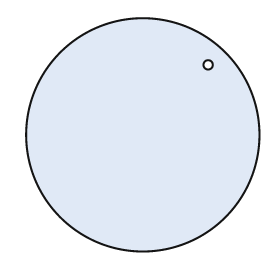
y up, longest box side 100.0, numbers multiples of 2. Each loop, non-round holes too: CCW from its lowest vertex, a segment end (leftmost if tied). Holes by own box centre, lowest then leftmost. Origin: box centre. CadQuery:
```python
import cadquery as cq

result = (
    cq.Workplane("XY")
    .moveTo(0.0, 0.0)
    .circle(50.0)
    .moveTo(28.0, 30.0)
    .circle(2.0)
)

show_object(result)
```